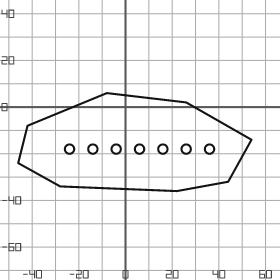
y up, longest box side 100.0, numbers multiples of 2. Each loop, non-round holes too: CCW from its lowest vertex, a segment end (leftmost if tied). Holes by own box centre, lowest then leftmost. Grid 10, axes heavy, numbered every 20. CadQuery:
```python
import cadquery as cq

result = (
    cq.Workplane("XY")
    .moveTo(22.0, -36.0)
    .lineTo(44.0, -32.0)
    .lineTo(54.0, -14.0)
    .lineTo(26.0, 2.0)
    .lineTo(-8.0, 6.0)
    .lineTo(-42.0, -8.0)
    .lineTo(-46.0, -24.0)
    .lineTo(-28.0, -34.0)
    .close()
    .moveTo(-24.0, -18.0)
    .circle(2.0)
    .moveTo(-14.0, -18.0)
    .circle(2.0)
    .moveTo(-4.0, -18.0)
    .circle(2.0)
    .moveTo(6.0, -18.0)
    .circle(2.0)
    .moveTo(16.0, -18.0)
    .circle(2.0)
    .moveTo(26.0, -18.0)
    .circle(2.0)
    .moveTo(36.0, -18.0)
    .circle(2.0)
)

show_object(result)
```